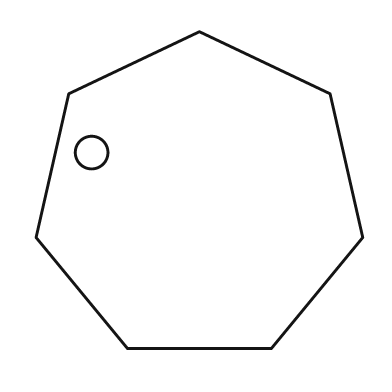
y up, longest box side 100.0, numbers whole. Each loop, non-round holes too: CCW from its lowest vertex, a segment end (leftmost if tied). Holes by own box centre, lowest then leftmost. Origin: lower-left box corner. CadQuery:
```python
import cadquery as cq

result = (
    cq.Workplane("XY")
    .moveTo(28.0, 0.0)
    .lineTo(72.0, 0.0)
    .lineTo(100.0, 34.0)
    .lineTo(90.0, 78.0)
    .lineTo(50.0, 97.0)
    .lineTo(10.0, 78.0)
    .lineTo(0.0, 34.0)
    .close()
    .moveTo(17.0, 60.0)
    .circle(5.0)
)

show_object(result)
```